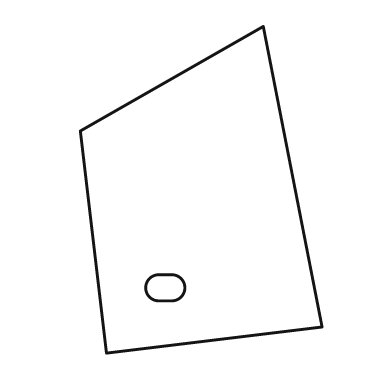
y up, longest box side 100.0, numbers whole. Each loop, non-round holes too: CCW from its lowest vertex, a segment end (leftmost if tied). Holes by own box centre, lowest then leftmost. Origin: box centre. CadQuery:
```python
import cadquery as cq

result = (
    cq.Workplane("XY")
    .moveTo(-29.0, -50.0)
    .lineTo(37.0, -42.0)
    .lineTo(19.0, 50.0)
    .lineTo(-37.0, 18.0)
    .close()
    .moveTo(-13.0, -34.0)
    .lineTo(-9.0, -34.0)
    .threePointArc((-5.0, -30.0), (-9.0, -26.0))
    .lineTo(-13.0, -26.0)
    .threePointArc((-17.0, -30.0), (-13.0, -34.0))
    .close()
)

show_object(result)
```